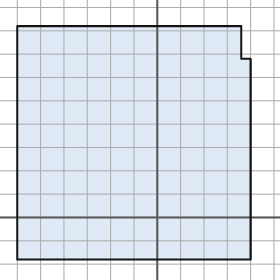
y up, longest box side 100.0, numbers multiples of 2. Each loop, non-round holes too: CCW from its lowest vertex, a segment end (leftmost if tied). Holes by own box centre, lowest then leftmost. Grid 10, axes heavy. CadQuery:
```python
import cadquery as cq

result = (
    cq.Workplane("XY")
    .moveTo(-60.0, -18.0)
    .lineTo(40.0, -18.0)
    .lineTo(40.0, 68.0)
    .lineTo(36.0, 68.0)
    .lineTo(36.0, 82.0)
    .lineTo(-60.0, 82.0)
    .close()
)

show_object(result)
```